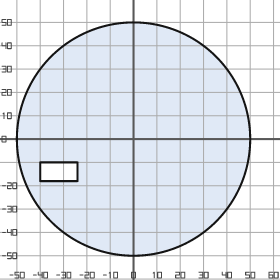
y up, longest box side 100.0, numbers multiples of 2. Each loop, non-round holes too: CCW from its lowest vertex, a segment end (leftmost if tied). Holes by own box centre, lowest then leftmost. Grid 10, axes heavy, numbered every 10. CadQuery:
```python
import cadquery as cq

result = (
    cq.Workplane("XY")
    .moveTo(0.0, 0.0)
    .circle(50.0)
    .moveTo(-40.0, -18.0)
    .lineTo(-24.0, -18.0)
    .lineTo(-24.0, -10.0)
    .lineTo(-40.0, -10.0)
    .close()
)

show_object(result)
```